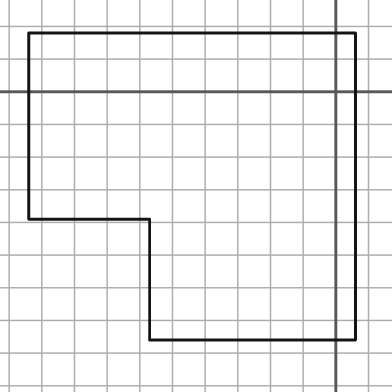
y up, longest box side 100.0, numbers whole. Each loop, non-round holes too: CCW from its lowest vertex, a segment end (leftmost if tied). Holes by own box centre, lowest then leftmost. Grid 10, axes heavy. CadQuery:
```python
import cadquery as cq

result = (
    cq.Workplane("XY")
    .moveTo(-57.0, -76.0)
    .lineTo(6.0, -76.0)
    .lineTo(6.0, 18.0)
    .lineTo(-94.0, 18.0)
    .lineTo(-94.0, -39.0)
    .lineTo(-57.0, -39.0)
    .close()
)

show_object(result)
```